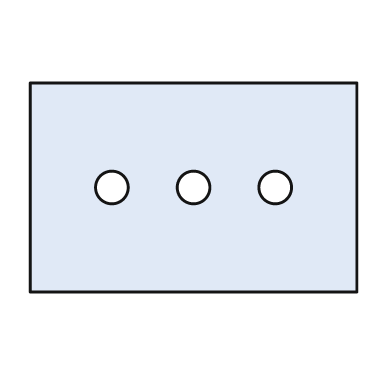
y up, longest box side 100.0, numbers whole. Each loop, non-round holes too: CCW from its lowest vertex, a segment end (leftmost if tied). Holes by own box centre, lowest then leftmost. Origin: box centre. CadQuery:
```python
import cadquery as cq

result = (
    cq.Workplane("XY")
    .moveTo(-50.0, -32.0)
    .lineTo(50.0, -32.0)
    .lineTo(50.0, 32.0)
    .lineTo(-50.0, 32.0)
    .close()
    .moveTo(-25.0, 0.0)
    .circle(5.0)
    .moveTo(0.0, 0.0)
    .circle(5.0)
    .moveTo(25.0, 0.0)
    .circle(5.0)
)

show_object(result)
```